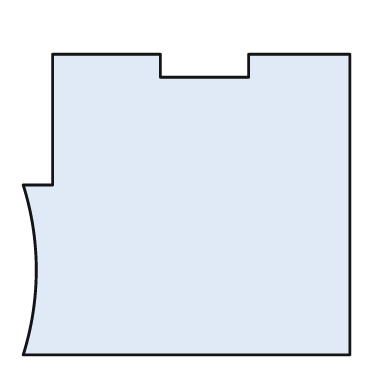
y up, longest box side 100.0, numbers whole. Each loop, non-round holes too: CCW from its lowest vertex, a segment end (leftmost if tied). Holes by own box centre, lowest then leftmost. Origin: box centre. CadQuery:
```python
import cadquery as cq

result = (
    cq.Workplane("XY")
    .moveTo(-50.0, -46.0)
    .lineTo(50.0, -46.0)
    .lineTo(50.0, 46.0)
    .lineTo(19.0, 46.0)
    .lineTo(19.0, 39.0)
    .lineTo(-8.0, 39.0)
    .lineTo(-8.0, 46.0)
    .lineTo(-41.0, 46.0)
    .lineTo(-41.0, 6.0)
    .lineTo(-50.0, 6.0)
    .threePointArc((-46.0, -20.0), (-50.0, -46.0))
    .close()
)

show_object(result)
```